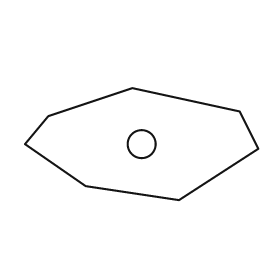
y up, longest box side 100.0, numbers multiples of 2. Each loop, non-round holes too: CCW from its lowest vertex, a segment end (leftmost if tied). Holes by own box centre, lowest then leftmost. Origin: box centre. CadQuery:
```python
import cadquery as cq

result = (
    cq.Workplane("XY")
    .moveTo(16.0, -24.0)
    .lineTo(50.0, -2.0)
    .lineTo(42.0, 14.0)
    .lineTo(-4.0, 24.0)
    .lineTo(-40.0, 12.0)
    .lineTo(-50.0, 0.0)
    .lineTo(-24.0, -18.0)
    .close()
    .moveTo(0.0, 0.0)
    .circle(6.0)
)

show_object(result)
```